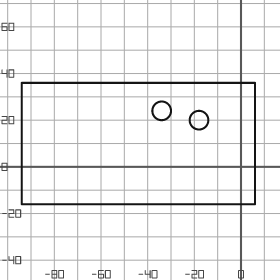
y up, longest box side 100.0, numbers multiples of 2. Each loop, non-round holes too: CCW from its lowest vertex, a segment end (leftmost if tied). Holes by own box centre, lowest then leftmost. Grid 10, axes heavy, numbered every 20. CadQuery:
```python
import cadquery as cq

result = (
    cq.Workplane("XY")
    .moveTo(-94.0, -16.0)
    .lineTo(6.0, -16.0)
    .lineTo(6.0, 36.0)
    .lineTo(-94.0, 36.0)
    .close()
    .moveTo(-18.0, 20.0)
    .circle(4.0)
    .moveTo(-34.0, 24.0)
    .circle(4.0)
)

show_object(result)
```